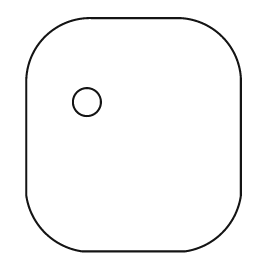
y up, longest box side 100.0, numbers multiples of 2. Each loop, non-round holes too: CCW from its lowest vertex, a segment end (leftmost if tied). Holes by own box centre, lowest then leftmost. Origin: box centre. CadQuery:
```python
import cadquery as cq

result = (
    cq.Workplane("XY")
    .moveTo(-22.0, -50.0)
    .lineTo(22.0, -50.0)
    .threePointArc((38.0, -42.0), (46.0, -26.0))
    .lineTo(46.0, 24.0)
    .threePointArc((38.0, 42.0), (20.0, 50.0))
    .lineTo(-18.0, 50.0)
    .threePointArc((-38.0, 42.0), (-46.0, 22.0))
    .lineTo(-46.0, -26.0)
    .threePointArc((-38.0, -42.0), (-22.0, -50.0))
    .close()
    .moveTo(-20.0, 14.0)
    .circle(6.0)
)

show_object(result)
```